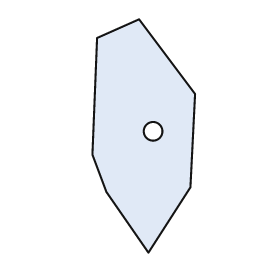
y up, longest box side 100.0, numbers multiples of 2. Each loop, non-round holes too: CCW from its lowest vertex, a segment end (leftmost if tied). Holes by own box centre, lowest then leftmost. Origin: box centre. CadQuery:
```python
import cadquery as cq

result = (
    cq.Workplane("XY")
    .moveTo(2.0, -50.0)
    .lineTo(20.0, -22.0)
    .lineTo(22.0, 18.0)
    .lineTo(-2.0, 50.0)
    .lineTo(-20.0, 42.0)
    .lineTo(-22.0, -8.0)
    .lineTo(-16.0, -24.0)
    .close()
    .moveTo(4.0, 2.0)
    .circle(4.0)
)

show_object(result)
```